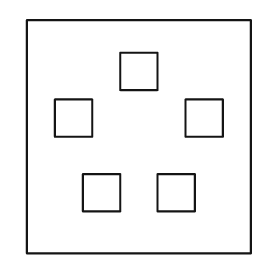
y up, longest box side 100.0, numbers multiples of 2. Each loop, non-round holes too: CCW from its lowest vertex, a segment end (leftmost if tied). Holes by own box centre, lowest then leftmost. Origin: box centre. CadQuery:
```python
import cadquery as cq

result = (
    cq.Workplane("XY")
    .moveTo(-48.0, -50.0)
    .lineTo(48.0, -50.0)
    .lineTo(48.0, 50.0)
    .lineTo(-48.0, 50.0)
    .close()
    .moveTo(-24.0, -32.0)
    .lineTo(-8.0, -32.0)
    .lineTo(-8.0, -16.0)
    .lineTo(-24.0, -16.0)
    .close()
    .moveTo(8.0, -32.0)
    .lineTo(24.0, -32.0)
    .lineTo(24.0, -16.0)
    .lineTo(8.0, -16.0)
    .close()
    .moveTo(-36.0, 0.0)
    .lineTo(-20.0, 0.0)
    .lineTo(-20.0, 16.0)
    .lineTo(-36.0, 16.0)
    .close()
    .moveTo(20.0, 0.0)
    .lineTo(36.0, 0.0)
    .lineTo(36.0, 16.0)
    .lineTo(20.0, 16.0)
    .close()
    .moveTo(-8.0, 20.0)
    .lineTo(8.0, 20.0)
    .lineTo(8.0, 36.0)
    .lineTo(-8.0, 36.0)
    .close()
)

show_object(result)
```